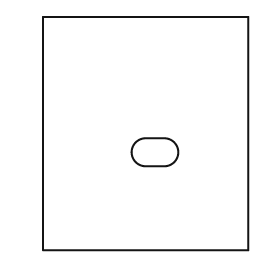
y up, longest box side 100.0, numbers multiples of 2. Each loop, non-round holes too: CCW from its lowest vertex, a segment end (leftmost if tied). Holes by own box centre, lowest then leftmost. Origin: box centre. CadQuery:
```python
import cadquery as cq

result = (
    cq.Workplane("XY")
    .moveTo(-44.0, -50.0)
    .lineTo(44.0, -50.0)
    .lineTo(44.0, 50.0)
    .lineTo(-44.0, 50.0)
    .close()
    .moveTo(0.0, -14.0)
    .lineTo(8.0, -14.0)
    .threePointArc((14.0, -8.0), (8.0, -2.0))
    .lineTo(0.0, -2.0)
    .threePointArc((-6.0, -8.0), (0.0, -14.0))
    .close()
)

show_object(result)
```